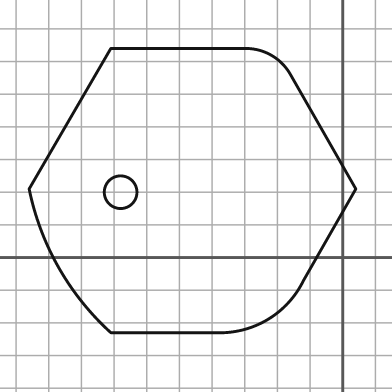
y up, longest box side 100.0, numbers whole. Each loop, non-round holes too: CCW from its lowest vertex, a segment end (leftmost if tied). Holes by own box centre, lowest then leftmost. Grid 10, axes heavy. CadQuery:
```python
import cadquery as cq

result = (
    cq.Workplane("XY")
    .moveTo(-71.0, -23.0)
    .lineTo(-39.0, -23.0)
    .threePointArc((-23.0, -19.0), (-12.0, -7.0))
    .lineTo(4.0, 21.0)
    .lineTo(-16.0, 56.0)
    .threePointArc((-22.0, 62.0), (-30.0, 64.0))
    .lineTo(-71.0, 64.0)
    .lineTo(-96.0, 21.0)
    .threePointArc((-87.0, -3.0), (-71.0, -23.0))
    .close()
    .moveTo(-68.0, 20.0)
    .circle(5.0)
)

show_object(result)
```